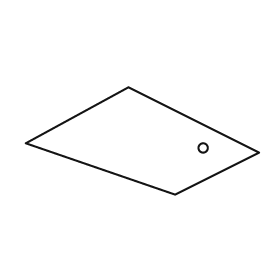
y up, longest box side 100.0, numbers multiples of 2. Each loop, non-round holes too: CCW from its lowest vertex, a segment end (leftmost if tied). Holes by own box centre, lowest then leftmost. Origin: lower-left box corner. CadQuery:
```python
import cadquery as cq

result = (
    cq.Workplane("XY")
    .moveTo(64.0, 0.0)
    .lineTo(100.0, 18.0)
    .lineTo(44.0, 46.0)
    .lineTo(0.0, 22.0)
    .close()
    .moveTo(76.0, 20.0)
    .circle(2.0)
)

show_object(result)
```